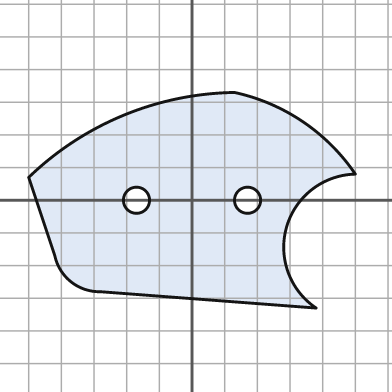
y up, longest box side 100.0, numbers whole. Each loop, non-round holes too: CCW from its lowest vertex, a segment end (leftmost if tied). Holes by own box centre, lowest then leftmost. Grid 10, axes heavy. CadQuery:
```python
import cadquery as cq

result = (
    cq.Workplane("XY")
    .moveTo(38.0, -33.0)
    .threePointArc((29.0, -8.0), (50.0, 8.0))
    .threePointArc((34.0, 24.0), (13.0, 33.0))
    .threePointArc((-21.0, 26.0), (-50.0, 7.0))
    .lineTo(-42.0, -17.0)
    .threePointArc((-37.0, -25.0), (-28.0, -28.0))
    .close()
    .moveTo(-17.0, 0.0)
    .circle(4.0)
    .moveTo(17.0, 0.0)
    .circle(4.0)
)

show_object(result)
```